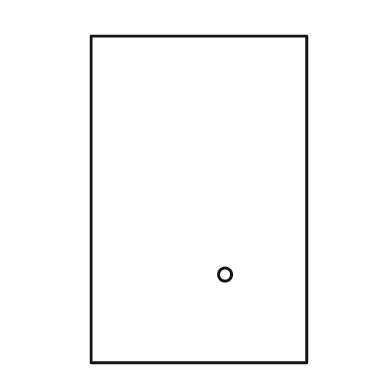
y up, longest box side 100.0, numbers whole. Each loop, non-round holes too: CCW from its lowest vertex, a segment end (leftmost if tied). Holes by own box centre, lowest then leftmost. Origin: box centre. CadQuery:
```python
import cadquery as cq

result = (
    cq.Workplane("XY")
    .moveTo(-33.0, -50.0)
    .lineTo(33.0, -50.0)
    .lineTo(33.0, 50.0)
    .lineTo(-33.0, 50.0)
    .close()
    .moveTo(8.0, -23.0)
    .circle(2.0)
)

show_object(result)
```